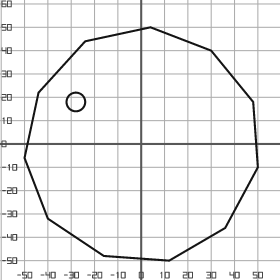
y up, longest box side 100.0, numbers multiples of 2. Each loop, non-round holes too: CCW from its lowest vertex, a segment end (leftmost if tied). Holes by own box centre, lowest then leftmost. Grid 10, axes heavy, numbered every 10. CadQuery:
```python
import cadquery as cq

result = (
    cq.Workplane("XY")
    .moveTo(12.0, -50.0)
    .lineTo(36.0, -36.0)
    .lineTo(50.0, -10.0)
    .lineTo(48.0, 18.0)
    .lineTo(30.0, 40.0)
    .lineTo(4.0, 50.0)
    .lineTo(-24.0, 44.0)
    .lineTo(-44.0, 22.0)
    .lineTo(-50.0, -6.0)
    .lineTo(-40.0, -32.0)
    .lineTo(-16.0, -48.0)
    .close()
    .moveTo(-28.0, 18.0)
    .circle(4.0)
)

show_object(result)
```